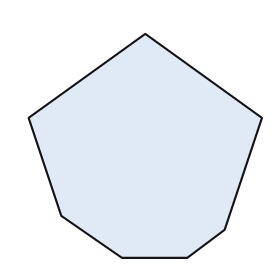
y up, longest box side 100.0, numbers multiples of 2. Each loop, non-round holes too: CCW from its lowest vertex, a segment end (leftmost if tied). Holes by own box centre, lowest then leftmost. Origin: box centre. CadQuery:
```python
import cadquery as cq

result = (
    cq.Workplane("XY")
    .moveTo(-10.0, -48.0)
    .lineTo(18.0, -48.0)
    .lineTo(34.0, -36.0)
    .lineTo(50.0, 12.0)
    .lineTo(0.0, 48.0)
    .lineTo(-50.0, 12.0)
    .lineTo(-36.0, -30.0)
    .close()
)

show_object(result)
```